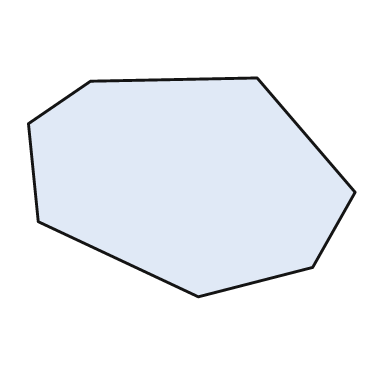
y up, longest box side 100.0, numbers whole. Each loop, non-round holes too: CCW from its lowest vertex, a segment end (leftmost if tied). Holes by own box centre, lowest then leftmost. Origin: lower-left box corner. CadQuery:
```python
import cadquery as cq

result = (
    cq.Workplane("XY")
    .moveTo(52.0, 0.0)
    .lineTo(87.0, 9.0)
    .lineTo(100.0, 32.0)
    .lineTo(70.0, 67.0)
    .lineTo(19.0, 66.0)
    .lineTo(0.0, 53.0)
    .lineTo(3.0, 23.0)
    .close()
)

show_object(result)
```